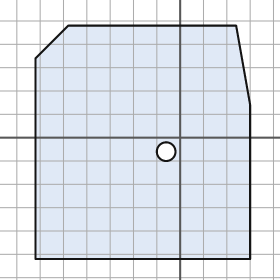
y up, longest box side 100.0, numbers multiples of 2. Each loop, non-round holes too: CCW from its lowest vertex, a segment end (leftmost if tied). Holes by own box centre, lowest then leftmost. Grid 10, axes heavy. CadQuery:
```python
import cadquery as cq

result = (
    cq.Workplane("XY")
    .moveTo(-62.0, -52.0)
    .lineTo(30.0, -52.0)
    .lineTo(30.0, 14.0)
    .lineTo(24.0, 48.0)
    .lineTo(-48.0, 48.0)
    .lineTo(-62.0, 34.0)
    .close()
    .moveTo(-6.0, -6.0)
    .circle(4.0)
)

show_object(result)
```